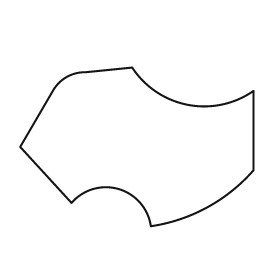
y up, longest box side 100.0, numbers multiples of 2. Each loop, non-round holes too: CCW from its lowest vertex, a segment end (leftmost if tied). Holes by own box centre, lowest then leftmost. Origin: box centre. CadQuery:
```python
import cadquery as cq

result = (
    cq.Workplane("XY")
    .moveTo(6.0, -34.0)
    .threePointArc((30.0, -26.0), (50.0, -10.0))
    .lineTo(50.0, 24.0)
    .threePointArc((22.0, 18.0), (-2.0, 34.0))
    .lineTo(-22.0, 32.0)
    .threePointArc((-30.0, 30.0), (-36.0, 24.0))
    .lineTo(-50.0, 0.0)
    .lineTo(-28.0, -24.0)
    .threePointArc((-8.0, -18.0), (6.0, -34.0))
    .close()
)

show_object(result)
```